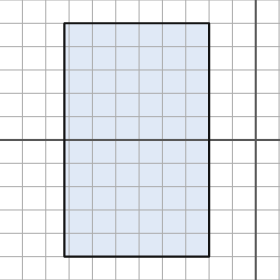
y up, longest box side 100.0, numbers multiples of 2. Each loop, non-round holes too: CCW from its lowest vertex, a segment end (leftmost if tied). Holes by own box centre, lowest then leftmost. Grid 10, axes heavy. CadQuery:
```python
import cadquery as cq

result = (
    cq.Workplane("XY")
    .moveTo(-82.0, -50.0)
    .lineTo(-20.0, -50.0)
    .lineTo(-20.0, 50.0)
    .lineTo(-82.0, 50.0)
    .close()
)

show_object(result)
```